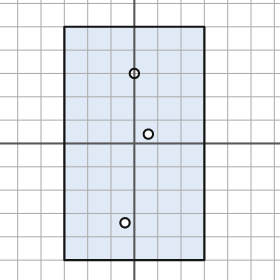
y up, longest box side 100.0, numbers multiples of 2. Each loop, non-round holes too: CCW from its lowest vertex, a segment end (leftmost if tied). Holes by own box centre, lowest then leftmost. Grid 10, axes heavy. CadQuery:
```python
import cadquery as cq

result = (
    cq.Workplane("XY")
    .moveTo(-30.0, -50.0)
    .lineTo(30.0, -50.0)
    .lineTo(30.0, 50.0)
    .lineTo(-30.0, 50.0)
    .close()
    .moveTo(-4.0, -34.0)
    .circle(2.0)
    .moveTo(6.0, 4.0)
    .circle(2.0)
    .moveTo(0.0, 30.0)
    .circle(2.0)
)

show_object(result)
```